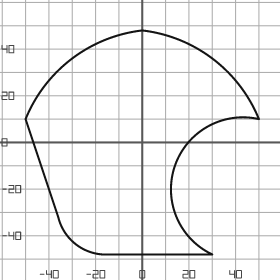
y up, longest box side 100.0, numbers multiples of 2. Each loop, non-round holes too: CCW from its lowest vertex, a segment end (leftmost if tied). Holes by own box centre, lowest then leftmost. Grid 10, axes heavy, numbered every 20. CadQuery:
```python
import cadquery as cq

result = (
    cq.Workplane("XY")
    .moveTo(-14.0, -48.0)
    .lineTo(30.0, -48.0)
    .threePointArc((14.0, -10.0), (50.0, 10.0))
    .threePointArc((30.0, 36.0), (0.0, 48.0))
    .threePointArc((-30.0, 36.0), (-50.0, 10.0))
    .lineTo(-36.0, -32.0)
    .threePointArc((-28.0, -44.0), (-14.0, -48.0))
    .close()
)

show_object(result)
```